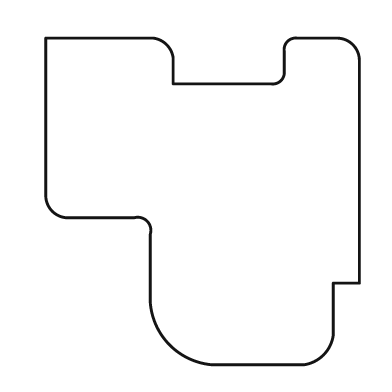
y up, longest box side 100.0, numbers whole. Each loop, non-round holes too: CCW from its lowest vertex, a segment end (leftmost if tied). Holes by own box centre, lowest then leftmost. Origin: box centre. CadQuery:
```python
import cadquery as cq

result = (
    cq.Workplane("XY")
    .moveTo(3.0, -50.0)
    .lineTo(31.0, -50.0)
    .threePointArc((37.0, -47.0), (40.0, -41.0))
    .lineTo(40.0, -25.0)
    .lineTo(48.0, -25.0)
    .lineTo(48.0, 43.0)
    .threePointArc((46.0, 48.0), (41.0, 50.0))
    .lineTo(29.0, 50.0)
    .threePointArc((26.0, 49.0), (25.0, 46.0))
    .lineTo(25.0, 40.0)
    .threePointArc((24.0, 37.0), (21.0, 36.0))
    .lineTo(-9.0, 36.0)
    .lineTo(-9.0, 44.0)
    .threePointArc((-11.0, 48.0), (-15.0, 50.0))
    .lineTo(-48.0, 50.0)
    .lineTo(-48.0, 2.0)
    .threePointArc((-46.0, -3.0), (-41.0, -5.0))
    .lineTo(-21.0, -5.0)
    .threePointArc((-17.0, -6.0), (-16.0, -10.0))
    .lineTo(-16.0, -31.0)
    .threePointArc((-10.0, -44.0), (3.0, -50.0))
    .close()
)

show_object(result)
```